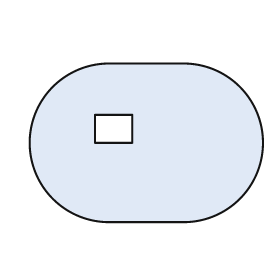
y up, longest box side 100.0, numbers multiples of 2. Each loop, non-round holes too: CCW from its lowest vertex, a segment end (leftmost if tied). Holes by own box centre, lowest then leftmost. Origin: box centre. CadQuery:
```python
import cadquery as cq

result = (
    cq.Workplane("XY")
    .moveTo(-16.0, -34.0)
    .lineTo(16.0, -34.0)
    .threePointArc((50.0, 0.0), (16.0, 34.0))
    .lineTo(-16.0, 34.0)
    .threePointArc((-50.0, 0.0), (-16.0, -34.0))
    .close()
    .moveTo(-22.0, 0.0)
    .lineTo(-6.0, 0.0)
    .lineTo(-6.0, 12.0)
    .lineTo(-22.0, 12.0)
    .close()
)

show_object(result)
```